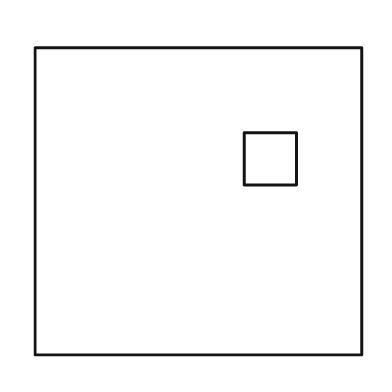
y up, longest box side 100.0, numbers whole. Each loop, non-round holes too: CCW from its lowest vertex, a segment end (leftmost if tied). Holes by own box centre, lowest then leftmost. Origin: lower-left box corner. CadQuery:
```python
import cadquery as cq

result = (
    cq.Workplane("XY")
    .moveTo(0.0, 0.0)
    .lineTo(100.0, 0.0)
    .lineTo(100.0, 94.0)
    .lineTo(0.0, 94.0)
    .close()
    .moveTo(64.0, 52.0)
    .lineTo(80.0, 52.0)
    .lineTo(80.0, 68.0)
    .lineTo(64.0, 68.0)
    .close()
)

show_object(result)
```